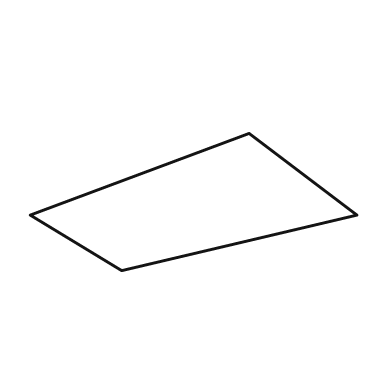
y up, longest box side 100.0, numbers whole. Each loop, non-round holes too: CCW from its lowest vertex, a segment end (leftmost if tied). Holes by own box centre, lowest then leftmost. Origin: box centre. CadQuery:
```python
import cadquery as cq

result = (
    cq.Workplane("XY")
    .moveTo(-22.0, -21.0)
    .lineTo(50.0, -4.0)
    .lineTo(17.0, 21.0)
    .lineTo(-50.0, -4.0)
    .close()
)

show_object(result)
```